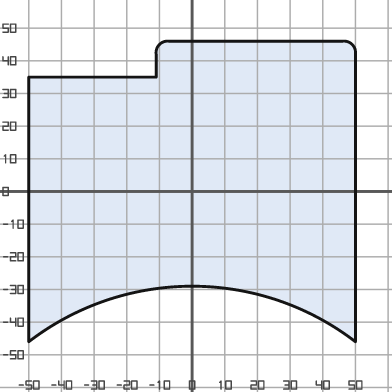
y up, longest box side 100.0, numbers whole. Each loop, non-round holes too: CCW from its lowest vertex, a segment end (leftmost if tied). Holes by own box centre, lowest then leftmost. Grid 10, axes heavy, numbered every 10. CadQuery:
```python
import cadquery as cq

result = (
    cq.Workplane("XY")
    .moveTo(-50.0, -46.0)
    .threePointArc((0.0, -29.0), (50.0, -46.0))
    .lineTo(50.0, 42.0)
    .threePointArc((49.0, 45.0), (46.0, 46.0))
    .lineTo(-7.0, 46.0)
    .threePointArc((-10.0, 45.0), (-11.0, 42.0))
    .lineTo(-11.0, 35.0)
    .lineTo(-50.0, 35.0)
    .close()
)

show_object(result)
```